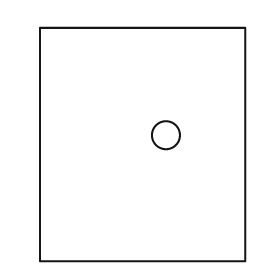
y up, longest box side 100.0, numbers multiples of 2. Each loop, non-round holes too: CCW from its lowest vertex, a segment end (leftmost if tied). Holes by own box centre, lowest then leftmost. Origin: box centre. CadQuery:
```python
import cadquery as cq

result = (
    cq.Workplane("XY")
    .moveTo(-44.0, -50.0)
    .lineTo(44.0, -50.0)
    .lineTo(44.0, 50.0)
    .lineTo(-44.0, 50.0)
    .close()
    .moveTo(10.0, 4.0)
    .circle(6.0)
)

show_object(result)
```